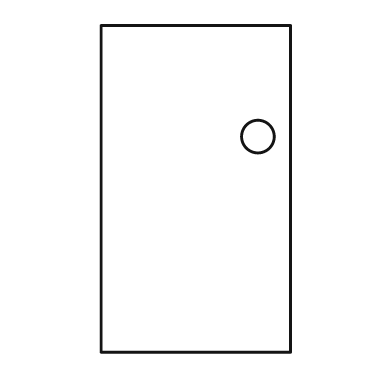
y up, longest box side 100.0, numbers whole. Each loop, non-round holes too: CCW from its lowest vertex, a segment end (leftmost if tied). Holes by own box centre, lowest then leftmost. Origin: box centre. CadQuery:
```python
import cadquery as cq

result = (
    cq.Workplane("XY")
    .moveTo(-29.0, -50.0)
    .lineTo(29.0, -50.0)
    .lineTo(29.0, 50.0)
    .lineTo(-29.0, 50.0)
    .close()
    .moveTo(19.0, 16.0)
    .circle(5.0)
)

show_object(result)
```